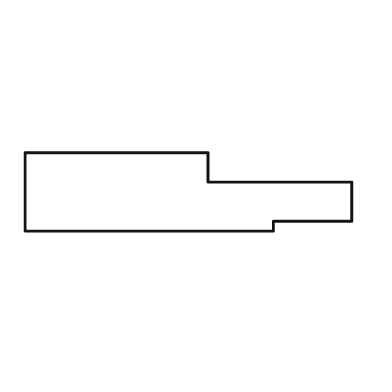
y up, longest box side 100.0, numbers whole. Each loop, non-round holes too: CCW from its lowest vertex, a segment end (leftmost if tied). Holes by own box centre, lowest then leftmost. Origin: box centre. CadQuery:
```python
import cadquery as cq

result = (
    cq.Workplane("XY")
    .moveTo(-50.0, -12.0)
    .lineTo(26.0, -12.0)
    .lineTo(26.0, -9.0)
    .lineTo(50.0, -9.0)
    .lineTo(50.0, 3.0)
    .lineTo(6.0, 3.0)
    .lineTo(6.0, 12.0)
    .lineTo(-50.0, 12.0)
    .close()
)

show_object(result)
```